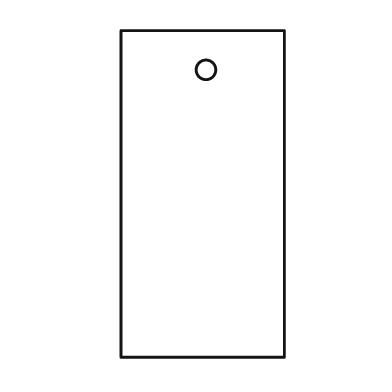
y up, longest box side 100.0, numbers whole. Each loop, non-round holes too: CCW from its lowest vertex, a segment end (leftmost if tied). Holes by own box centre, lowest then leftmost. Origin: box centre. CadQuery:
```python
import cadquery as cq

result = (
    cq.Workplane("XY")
    .moveTo(-25.0, -50.0)
    .lineTo(25.0, -50.0)
    .lineTo(25.0, 50.0)
    .lineTo(-25.0, 50.0)
    .close()
    .moveTo(1.0, 38.0)
    .circle(3.0)
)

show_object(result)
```